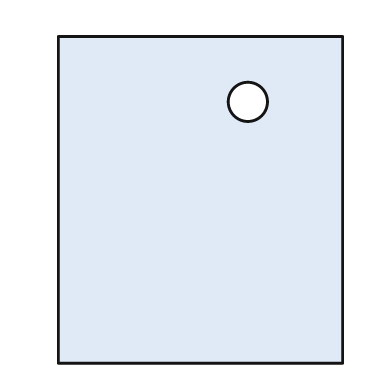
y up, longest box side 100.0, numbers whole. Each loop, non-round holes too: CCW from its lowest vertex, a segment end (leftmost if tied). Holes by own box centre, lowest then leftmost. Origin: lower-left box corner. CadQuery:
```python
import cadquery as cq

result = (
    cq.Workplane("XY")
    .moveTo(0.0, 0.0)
    .lineTo(87.0, 0.0)
    .lineTo(87.0, 100.0)
    .lineTo(0.0, 100.0)
    .close()
    .moveTo(58.0, 80.0)
    .circle(6.0)
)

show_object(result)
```